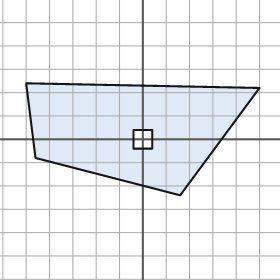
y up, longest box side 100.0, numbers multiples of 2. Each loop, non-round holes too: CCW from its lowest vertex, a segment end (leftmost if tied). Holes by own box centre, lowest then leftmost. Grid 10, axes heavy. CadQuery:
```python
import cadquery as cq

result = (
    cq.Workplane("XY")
    .moveTo(16.0, -24.0)
    .lineTo(50.0, 22.0)
    .lineTo(-50.0, 24.0)
    .lineTo(-46.0, -8.0)
    .close()
    .moveTo(-4.0, -4.0)
    .lineTo(4.0, -4.0)
    .lineTo(4.0, 4.0)
    .lineTo(-4.0, 4.0)
    .close()
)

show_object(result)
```